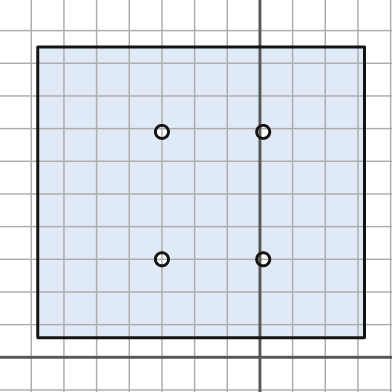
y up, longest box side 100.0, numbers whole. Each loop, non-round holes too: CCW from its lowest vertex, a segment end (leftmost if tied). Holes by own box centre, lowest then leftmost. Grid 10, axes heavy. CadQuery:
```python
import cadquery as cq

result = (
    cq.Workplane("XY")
    .moveTo(-68.0, 6.0)
    .lineTo(32.0, 6.0)
    .lineTo(32.0, 95.0)
    .lineTo(-68.0, 95.0)
    .close()
    .moveTo(-30.0, 30.0)
    .circle(2.0)
    .moveTo(1.0, 30.0)
    .circle(2.0)
    .moveTo(-30.0, 69.0)
    .circle(2.0)
    .moveTo(1.0, 69.0)
    .circle(2.0)
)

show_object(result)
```